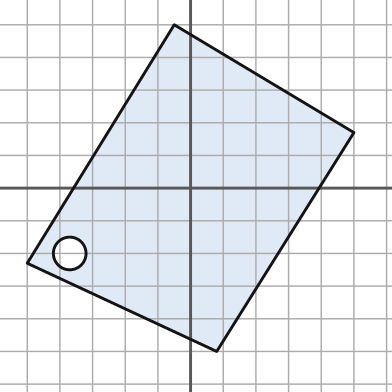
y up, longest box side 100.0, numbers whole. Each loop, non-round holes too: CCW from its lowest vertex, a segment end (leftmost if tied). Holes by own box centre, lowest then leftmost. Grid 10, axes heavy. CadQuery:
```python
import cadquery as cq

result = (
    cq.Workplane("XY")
    .moveTo(8.0, -50.0)
    .lineTo(50.0, 17.0)
    .lineTo(-5.0, 50.0)
    .lineTo(-50.0, -23.0)
    .close()
    .moveTo(-37.0, -20.0)
    .circle(5.0)
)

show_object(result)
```